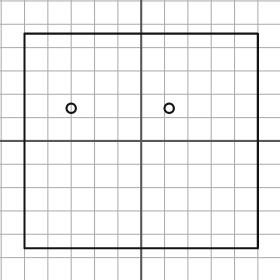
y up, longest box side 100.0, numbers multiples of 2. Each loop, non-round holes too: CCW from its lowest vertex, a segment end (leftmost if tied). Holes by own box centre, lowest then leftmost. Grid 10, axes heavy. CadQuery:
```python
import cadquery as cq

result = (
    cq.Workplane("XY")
    .moveTo(-50.0, -46.0)
    .lineTo(50.0, -46.0)
    .lineTo(50.0, 46.0)
    .lineTo(-50.0, 46.0)
    .close()
    .moveTo(-30.0, 14.0)
    .circle(2.0)
    .moveTo(12.0, 14.0)
    .circle(2.0)
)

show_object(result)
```